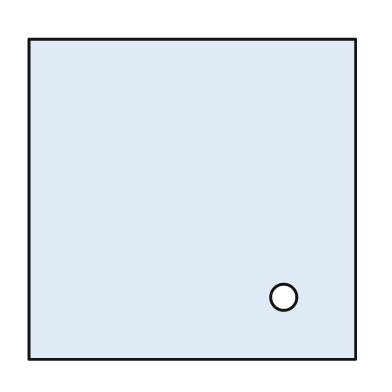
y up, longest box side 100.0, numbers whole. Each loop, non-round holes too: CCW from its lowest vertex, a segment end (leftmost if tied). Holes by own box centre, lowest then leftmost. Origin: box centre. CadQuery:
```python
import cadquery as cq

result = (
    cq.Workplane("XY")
    .moveTo(-50.0, -49.0)
    .lineTo(50.0, -49.0)
    .lineTo(50.0, 49.0)
    .lineTo(-50.0, 49.0)
    .close()
    .moveTo(28.0, -30.0)
    .circle(4.0)
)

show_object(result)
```